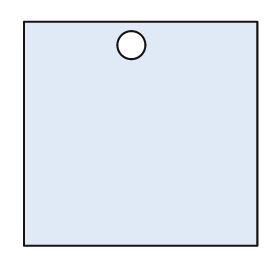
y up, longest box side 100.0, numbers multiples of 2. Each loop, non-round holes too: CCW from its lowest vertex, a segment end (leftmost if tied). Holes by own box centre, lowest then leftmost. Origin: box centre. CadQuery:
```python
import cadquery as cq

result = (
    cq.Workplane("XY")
    .moveTo(-50.0, -48.0)
    .lineTo(50.0, -48.0)
    .lineTo(50.0, 48.0)
    .lineTo(-50.0, 48.0)
    .close()
    .moveTo(-4.0, 38.0)
    .circle(6.0)
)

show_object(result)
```